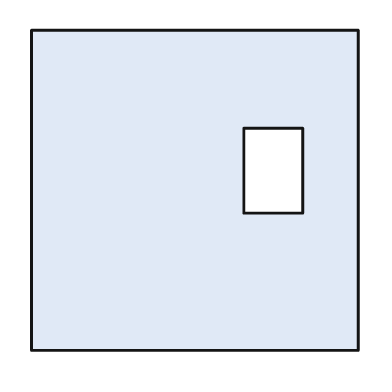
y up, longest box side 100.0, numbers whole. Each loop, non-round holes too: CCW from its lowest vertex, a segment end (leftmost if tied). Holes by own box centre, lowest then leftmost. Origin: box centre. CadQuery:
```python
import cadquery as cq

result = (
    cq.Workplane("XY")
    .moveTo(-50.0, -49.0)
    .lineTo(50.0, -49.0)
    .lineTo(50.0, 49.0)
    .lineTo(-50.0, 49.0)
    .close()
    .moveTo(15.0, -7.0)
    .lineTo(33.0, -7.0)
    .lineTo(33.0, 19.0)
    .lineTo(15.0, 19.0)
    .close()
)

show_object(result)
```